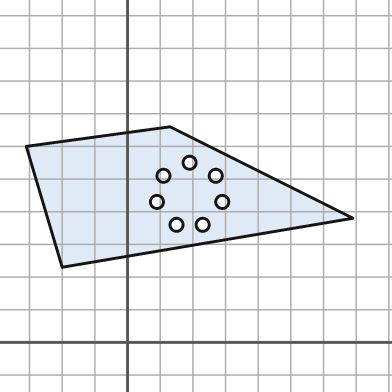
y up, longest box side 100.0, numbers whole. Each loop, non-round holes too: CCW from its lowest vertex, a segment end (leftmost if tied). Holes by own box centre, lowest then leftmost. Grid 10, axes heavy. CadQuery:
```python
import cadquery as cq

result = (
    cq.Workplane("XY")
    .moveTo(-20.0, 23.0)
    .lineTo(69.0, 38.0)
    .lineTo(13.0, 66.0)
    .lineTo(-31.0, 60.0)
    .close()
    .moveTo(15.0, 36.0)
    .circle(2.0)
    .moveTo(23.0, 36.0)
    .circle(2.0)
    .moveTo(9.0, 43.0)
    .circle(2.0)
    .moveTo(29.0, 43.0)
    .circle(2.0)
    .moveTo(11.0, 51.0)
    .circle(2.0)
    .moveTo(27.0, 51.0)
    .circle(2.0)
    .moveTo(19.0, 55.0)
    .circle(2.0)
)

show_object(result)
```